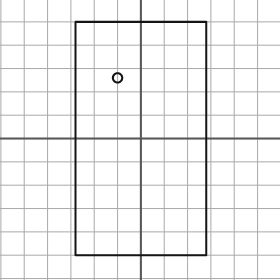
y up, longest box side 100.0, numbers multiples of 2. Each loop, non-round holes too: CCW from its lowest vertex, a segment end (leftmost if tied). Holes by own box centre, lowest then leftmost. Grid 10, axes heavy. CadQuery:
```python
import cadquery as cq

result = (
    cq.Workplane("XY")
    .moveTo(-28.0, -50.0)
    .lineTo(28.0, -50.0)
    .lineTo(28.0, 50.0)
    .lineTo(-28.0, 50.0)
    .close()
    .moveTo(-10.0, 26.0)
    .circle(2.0)
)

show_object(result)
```